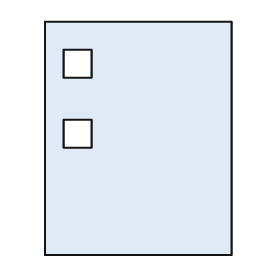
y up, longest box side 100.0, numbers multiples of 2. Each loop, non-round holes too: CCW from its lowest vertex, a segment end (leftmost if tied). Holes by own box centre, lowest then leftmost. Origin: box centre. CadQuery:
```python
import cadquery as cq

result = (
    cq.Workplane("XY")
    .moveTo(-40.0, -50.0)
    .lineTo(40.0, -50.0)
    .lineTo(40.0, 50.0)
    .lineTo(-40.0, 50.0)
    .close()
    .moveTo(-32.0, -4.0)
    .lineTo(-20.0, -4.0)
    .lineTo(-20.0, 8.0)
    .lineTo(-32.0, 8.0)
    .close()
    .moveTo(-32.0, 26.0)
    .lineTo(-20.0, 26.0)
    .lineTo(-20.0, 38.0)
    .lineTo(-32.0, 38.0)
    .close()
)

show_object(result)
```